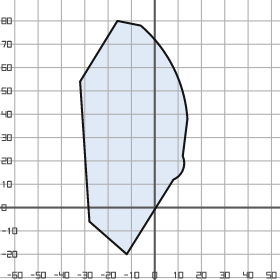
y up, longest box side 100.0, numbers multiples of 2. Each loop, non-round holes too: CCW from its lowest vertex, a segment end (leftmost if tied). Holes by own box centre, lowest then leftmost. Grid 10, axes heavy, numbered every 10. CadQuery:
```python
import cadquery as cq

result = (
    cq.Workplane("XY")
    .moveTo(-12.0, -20.0)
    .lineTo(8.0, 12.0)
    .threePointArc((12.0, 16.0), (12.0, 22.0))
    .lineTo(14.0, 38.0)
    .threePointArc((8.0, 60.0), (-6.0, 78.0))
    .lineTo(-16.0, 80.0)
    .lineTo(-32.0, 54.0)
    .lineTo(-28.0, -6.0)
    .close()
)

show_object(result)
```